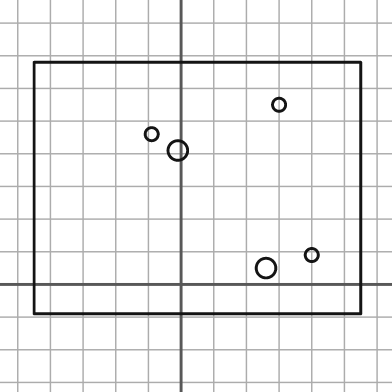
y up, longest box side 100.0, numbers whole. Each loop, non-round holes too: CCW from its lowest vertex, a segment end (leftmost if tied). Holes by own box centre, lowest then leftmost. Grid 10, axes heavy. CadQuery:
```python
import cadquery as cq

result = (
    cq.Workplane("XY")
    .moveTo(-45.0, -9.0)
    .lineTo(55.0, -9.0)
    .lineTo(55.0, 68.0)
    .lineTo(-45.0, 68.0)
    .close()
    .moveTo(26.0, 5.0)
    .circle(3.0)
    .moveTo(40.0, 9.0)
    .circle(2.0)
    .moveTo(-1.0, 41.0)
    .circle(3.0)
    .moveTo(-9.0, 46.0)
    .circle(2.0)
    .moveTo(30.0, 55.0)
    .circle(2.0)
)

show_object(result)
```